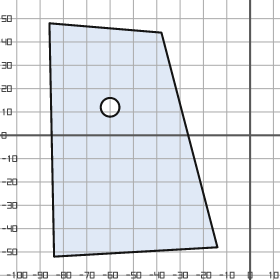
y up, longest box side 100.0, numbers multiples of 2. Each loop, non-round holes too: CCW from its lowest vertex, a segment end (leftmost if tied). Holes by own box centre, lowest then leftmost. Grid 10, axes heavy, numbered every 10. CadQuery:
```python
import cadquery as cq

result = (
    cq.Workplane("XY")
    .moveTo(-84.0, -52.0)
    .lineTo(-14.0, -48.0)
    .lineTo(-38.0, 44.0)
    .lineTo(-86.0, 48.0)
    .close()
    .moveTo(-60.0, 12.0)
    .circle(4.0)
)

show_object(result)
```